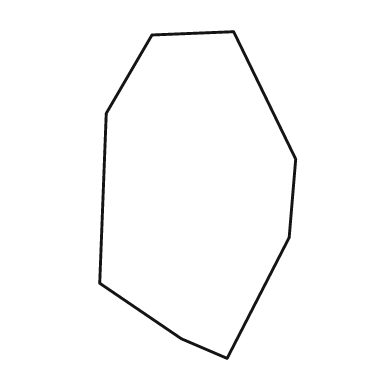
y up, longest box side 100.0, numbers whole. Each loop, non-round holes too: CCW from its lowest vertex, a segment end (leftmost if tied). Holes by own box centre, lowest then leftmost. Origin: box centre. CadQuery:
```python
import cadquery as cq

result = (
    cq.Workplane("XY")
    .moveTo(9.0, -50.0)
    .lineTo(28.0, -13.0)
    .lineTo(30.0, 11.0)
    .lineTo(11.0, 50.0)
    .lineTo(-14.0, 49.0)
    .lineTo(-28.0, 25.0)
    .lineTo(-30.0, -27.0)
    .lineTo(-5.0, -44.0)
    .close()
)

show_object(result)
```